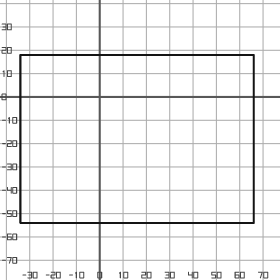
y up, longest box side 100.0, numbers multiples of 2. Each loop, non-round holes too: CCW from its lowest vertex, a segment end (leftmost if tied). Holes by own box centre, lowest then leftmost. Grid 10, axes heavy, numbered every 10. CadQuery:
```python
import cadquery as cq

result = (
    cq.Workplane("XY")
    .moveTo(-34.0, -54.0)
    .lineTo(66.0, -54.0)
    .lineTo(66.0, 18.0)
    .lineTo(-34.0, 18.0)
    .close()
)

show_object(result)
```